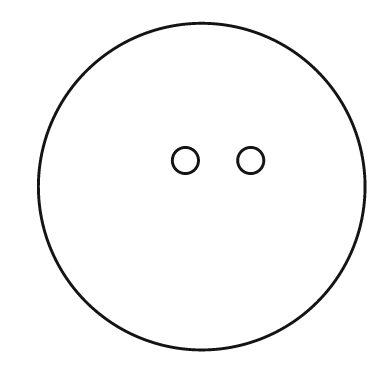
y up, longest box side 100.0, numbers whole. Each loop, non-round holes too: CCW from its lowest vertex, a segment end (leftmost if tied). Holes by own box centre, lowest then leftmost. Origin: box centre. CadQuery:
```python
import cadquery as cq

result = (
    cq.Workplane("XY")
    .moveTo(0.0, 0.0)
    .circle(50.0)
    .moveTo(-5.0, 8.0)
    .circle(4.0)
    .moveTo(15.0, 8.0)
    .circle(4.0)
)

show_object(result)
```